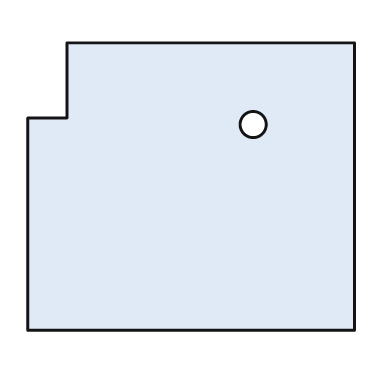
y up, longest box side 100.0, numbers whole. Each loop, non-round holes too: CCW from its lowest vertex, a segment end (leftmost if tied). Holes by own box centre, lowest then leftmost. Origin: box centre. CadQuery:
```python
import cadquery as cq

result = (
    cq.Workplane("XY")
    .moveTo(-50.0, -44.0)
    .lineTo(50.0, -44.0)
    .lineTo(50.0, 44.0)
    .lineTo(-38.0, 44.0)
    .lineTo(-38.0, 21.0)
    .lineTo(-50.0, 21.0)
    .close()
    .moveTo(19.0, 19.0)
    .circle(4.0)
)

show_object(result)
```